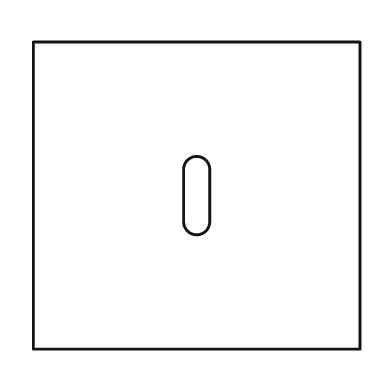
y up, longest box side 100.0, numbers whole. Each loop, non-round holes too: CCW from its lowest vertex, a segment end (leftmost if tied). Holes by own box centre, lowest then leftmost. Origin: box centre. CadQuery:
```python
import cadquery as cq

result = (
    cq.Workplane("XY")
    .moveTo(-50.0, -47.0)
    .lineTo(50.0, -47.0)
    .lineTo(50.0, 47.0)
    .lineTo(-50.0, 47.0)
    .close()
    .moveTo(-4.0, -8.0)
    .threePointArc((0.0, -12.0), (4.0, -8.0))
    .lineTo(4.0, 8.0)
    .threePointArc((0.0, 12.0), (-4.0, 8.0))
    .close()
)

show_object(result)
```